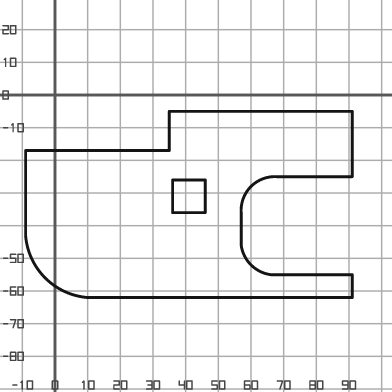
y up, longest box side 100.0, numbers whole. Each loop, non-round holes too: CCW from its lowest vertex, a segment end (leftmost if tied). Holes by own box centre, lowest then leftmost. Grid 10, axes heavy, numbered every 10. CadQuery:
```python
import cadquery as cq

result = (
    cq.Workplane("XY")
    .moveTo(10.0, -62.0)
    .lineTo(91.0, -62.0)
    .lineTo(91.0, -55.0)
    .lineTo(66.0, -55.0)
    .threePointArc((60.0, -52.0), (57.0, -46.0))
    .lineTo(57.0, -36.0)
    .threePointArc((60.0, -28.0), (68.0, -25.0))
    .lineTo(91.0, -25.0)
    .lineTo(91.0, -5.0)
    .lineTo(35.0, -5.0)
    .lineTo(35.0, -17.0)
    .lineTo(-9.0, -17.0)
    .lineTo(-9.0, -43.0)
    .threePointArc((-3.0, -56.0), (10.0, -62.0))
    .close()
    .moveTo(36.0, -36.0)
    .lineTo(46.0, -36.0)
    .lineTo(46.0, -26.0)
    .lineTo(36.0, -26.0)
    .close()
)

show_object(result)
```